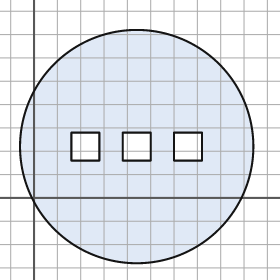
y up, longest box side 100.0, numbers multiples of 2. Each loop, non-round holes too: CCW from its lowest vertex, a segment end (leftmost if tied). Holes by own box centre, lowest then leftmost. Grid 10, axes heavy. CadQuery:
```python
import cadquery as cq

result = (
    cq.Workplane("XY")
    .moveTo(44.0, 22.0)
    .circle(50.0)
    .moveTo(16.0, 16.0)
    .lineTo(28.0, 16.0)
    .lineTo(28.0, 28.0)
    .lineTo(16.0, 28.0)
    .close()
    .moveTo(38.0, 16.0)
    .lineTo(50.0, 16.0)
    .lineTo(50.0, 28.0)
    .lineTo(38.0, 28.0)
    .close()
    .moveTo(60.0, 16.0)
    .lineTo(72.0, 16.0)
    .lineTo(72.0, 28.0)
    .lineTo(60.0, 28.0)
    .close()
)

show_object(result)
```